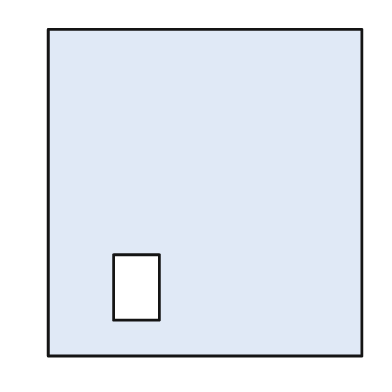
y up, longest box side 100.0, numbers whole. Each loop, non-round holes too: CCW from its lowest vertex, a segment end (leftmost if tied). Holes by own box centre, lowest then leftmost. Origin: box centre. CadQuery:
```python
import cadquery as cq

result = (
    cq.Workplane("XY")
    .moveTo(-48.0, -50.0)
    .lineTo(48.0, -50.0)
    .lineTo(48.0, 50.0)
    .lineTo(-48.0, 50.0)
    .close()
    .moveTo(-28.0, -39.0)
    .lineTo(-14.0, -39.0)
    .lineTo(-14.0, -19.0)
    .lineTo(-28.0, -19.0)
    .close()
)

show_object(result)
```